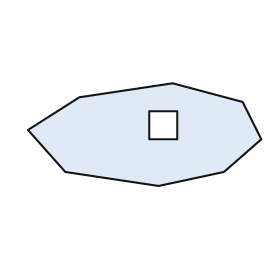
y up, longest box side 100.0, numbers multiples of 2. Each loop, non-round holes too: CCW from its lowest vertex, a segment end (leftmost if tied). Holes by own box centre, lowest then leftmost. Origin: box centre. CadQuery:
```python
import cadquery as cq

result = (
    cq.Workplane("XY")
    .moveTo(6.0, -22.0)
    .lineTo(34.0, -16.0)
    .lineTo(50.0, -2.0)
    .lineTo(42.0, 14.0)
    .lineTo(12.0, 22.0)
    .lineTo(-28.0, 16.0)
    .lineTo(-50.0, 2.0)
    .lineTo(-34.0, -16.0)
    .close()
    .moveTo(2.0, -2.0)
    .lineTo(14.0, -2.0)
    .lineTo(14.0, 10.0)
    .lineTo(2.0, 10.0)
    .close()
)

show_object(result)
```